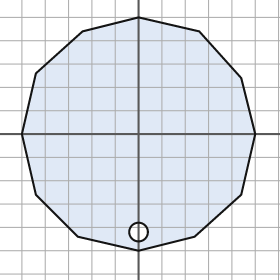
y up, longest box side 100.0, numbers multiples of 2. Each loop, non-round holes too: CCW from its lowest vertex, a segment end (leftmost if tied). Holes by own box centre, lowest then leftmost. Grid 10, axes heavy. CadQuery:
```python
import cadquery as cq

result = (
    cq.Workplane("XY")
    .moveTo(0.0, -50.0)
    .lineTo(24.0, -44.0)
    .lineTo(44.0, -26.0)
    .lineTo(50.0, 0.0)
    .lineTo(44.0, 24.0)
    .lineTo(26.0, 44.0)
    .lineTo(0.0, 50.0)
    .lineTo(-24.0, 44.0)
    .lineTo(-44.0, 26.0)
    .lineTo(-50.0, 0.0)
    .lineTo(-44.0, -26.0)
    .lineTo(-26.0, -44.0)
    .close()
    .moveTo(0.0, -42.0)
    .circle(4.0)
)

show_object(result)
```